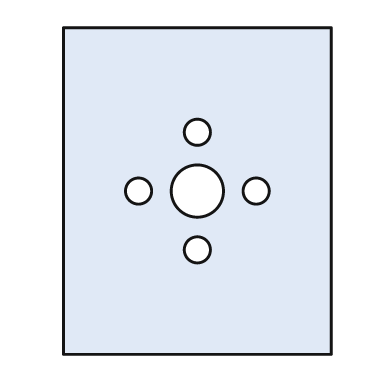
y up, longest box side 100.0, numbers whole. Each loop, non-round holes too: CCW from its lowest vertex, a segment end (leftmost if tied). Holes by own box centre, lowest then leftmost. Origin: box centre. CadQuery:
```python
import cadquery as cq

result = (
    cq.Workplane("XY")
    .moveTo(-41.0, -50.0)
    .lineTo(41.0, -50.0)
    .lineTo(41.0, 50.0)
    .lineTo(-41.0, 50.0)
    .close()
    .moveTo(0.0, -18.0)
    .circle(4.0)
    .moveTo(-18.0, 0.0)
    .circle(4.0)
    .moveTo(0.0, 0.0)
    .circle(8.0)
    .moveTo(18.0, 0.0)
    .circle(4.0)
    .moveTo(0.0, 18.0)
    .circle(4.0)
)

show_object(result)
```